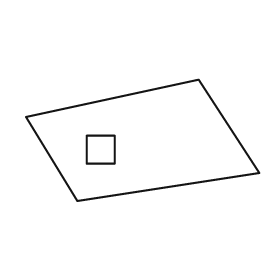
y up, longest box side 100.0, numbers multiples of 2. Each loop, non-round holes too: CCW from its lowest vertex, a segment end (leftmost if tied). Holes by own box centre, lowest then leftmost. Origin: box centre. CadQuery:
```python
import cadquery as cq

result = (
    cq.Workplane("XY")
    .moveTo(-28.0, -26.0)
    .lineTo(50.0, -14.0)
    .lineTo(24.0, 26.0)
    .lineTo(-50.0, 10.0)
    .close()
    .moveTo(-24.0, -10.0)
    .lineTo(-12.0, -10.0)
    .lineTo(-12.0, 2.0)
    .lineTo(-24.0, 2.0)
    .close()
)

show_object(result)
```